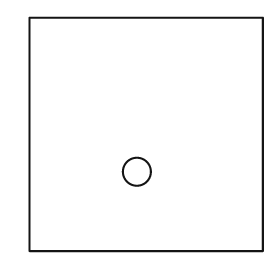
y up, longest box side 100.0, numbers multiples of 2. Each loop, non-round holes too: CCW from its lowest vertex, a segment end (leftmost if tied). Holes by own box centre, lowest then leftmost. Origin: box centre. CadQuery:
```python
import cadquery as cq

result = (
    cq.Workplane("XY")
    .moveTo(-50.0, -50.0)
    .lineTo(50.0, -50.0)
    .lineTo(50.0, 50.0)
    .lineTo(-50.0, 50.0)
    .close()
    .moveTo(-4.0, -16.0)
    .circle(6.0)
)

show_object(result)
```